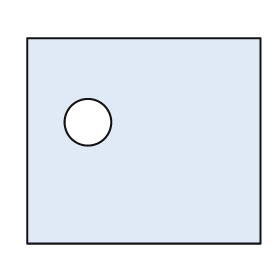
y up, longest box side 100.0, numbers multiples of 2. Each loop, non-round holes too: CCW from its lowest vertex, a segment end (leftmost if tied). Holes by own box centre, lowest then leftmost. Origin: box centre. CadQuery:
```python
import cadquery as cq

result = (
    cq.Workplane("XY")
    .moveTo(-50.0, -44.0)
    .lineTo(50.0, -44.0)
    .lineTo(50.0, 44.0)
    .lineTo(-50.0, 44.0)
    .close()
    .moveTo(-24.0, 8.0)
    .circle(10.0)
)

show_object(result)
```